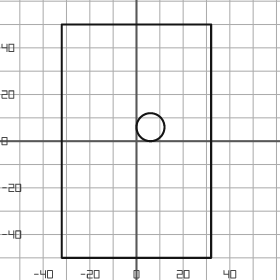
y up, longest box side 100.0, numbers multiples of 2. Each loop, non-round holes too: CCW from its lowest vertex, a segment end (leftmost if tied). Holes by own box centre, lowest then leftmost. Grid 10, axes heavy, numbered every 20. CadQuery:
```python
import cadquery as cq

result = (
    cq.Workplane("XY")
    .moveTo(-32.0, -50.0)
    .lineTo(32.0, -50.0)
    .lineTo(32.0, 50.0)
    .lineTo(-32.0, 50.0)
    .close()
    .moveTo(6.0, 6.0)
    .circle(6.0)
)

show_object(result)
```